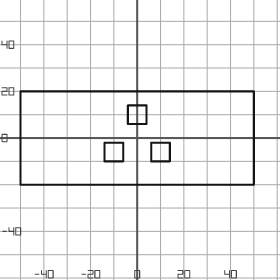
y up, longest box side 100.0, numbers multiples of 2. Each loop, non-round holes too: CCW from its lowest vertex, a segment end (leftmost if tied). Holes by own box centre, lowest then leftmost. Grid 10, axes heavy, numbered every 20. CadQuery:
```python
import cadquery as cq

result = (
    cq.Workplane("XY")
    .moveTo(-50.0, -20.0)
    .lineTo(50.0, -20.0)
    .lineTo(50.0, 20.0)
    .lineTo(-50.0, 20.0)
    .close()
    .moveTo(-14.0, -10.0)
    .lineTo(-6.0, -10.0)
    .lineTo(-6.0, -2.0)
    .lineTo(-14.0, -2.0)
    .close()
    .moveTo(6.0, -10.0)
    .lineTo(14.0, -10.0)
    .lineTo(14.0, -2.0)
    .lineTo(6.0, -2.0)
    .close()
    .moveTo(-4.0, 6.0)
    .lineTo(4.0, 6.0)
    .lineTo(4.0, 14.0)
    .lineTo(-4.0, 14.0)
    .close()
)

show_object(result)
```